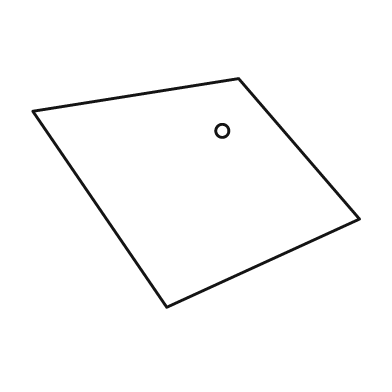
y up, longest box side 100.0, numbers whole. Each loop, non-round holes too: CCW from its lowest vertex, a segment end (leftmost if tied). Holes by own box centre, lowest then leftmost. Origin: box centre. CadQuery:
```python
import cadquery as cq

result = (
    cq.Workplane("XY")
    .moveTo(-9.0, -35.0)
    .lineTo(50.0, -8.0)
    .lineTo(13.0, 35.0)
    .lineTo(-50.0, 25.0)
    .close()
    .moveTo(8.0, 19.0)
    .circle(2.0)
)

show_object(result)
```